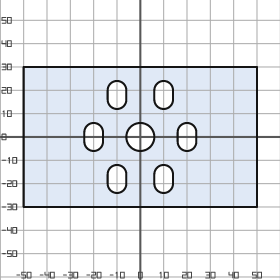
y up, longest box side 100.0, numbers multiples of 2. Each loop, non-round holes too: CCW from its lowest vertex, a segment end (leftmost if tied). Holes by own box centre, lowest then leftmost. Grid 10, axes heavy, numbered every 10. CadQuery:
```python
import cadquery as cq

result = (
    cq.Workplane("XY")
    .moveTo(-50.0, -30.0)
    .lineTo(50.0, -30.0)
    .lineTo(50.0, 30.0)
    .lineTo(-50.0, 30.0)
    .close()
    .moveTo(-14.0, -20.0)
    .threePointArc((-10.0, -24.0), (-6.0, -20.0))
    .lineTo(-6.0, -16.0)
    .threePointArc((-10.0, -12.0), (-14.0, -16.0))
    .close()
    .moveTo(6.0, -20.0)
    .threePointArc((10.0, -24.0), (14.0, -20.0))
    .lineTo(14.0, -16.0)
    .threePointArc((10.0, -12.0), (6.0, -16.0))
    .close()
    .moveTo(-24.0, -2.0)
    .threePointArc((-20.0, -6.0), (-16.0, -2.0))
    .lineTo(-16.0, 2.0)
    .threePointArc((-20.0, 6.0), (-24.0, 2.0))
    .close()
    .moveTo(0.0, 0.0)
    .circle(6.0)
    .moveTo(16.0, -2.0)
    .threePointArc((20.0, -6.0), (24.0, -2.0))
    .lineTo(24.0, 2.0)
    .threePointArc((20.0, 6.0), (16.0, 2.0))
    .close()
    .moveTo(-14.0, 16.0)
    .threePointArc((-10.0, 12.0), (-6.0, 16.0))
    .lineTo(-6.0, 20.0)
    .threePointArc((-10.0, 24.0), (-14.0, 20.0))
    .close()
    .moveTo(6.0, 16.0)
    .threePointArc((10.0, 12.0), (14.0, 16.0))
    .lineTo(14.0, 20.0)
    .threePointArc((10.0, 24.0), (6.0, 20.0))
    .close()
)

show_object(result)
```